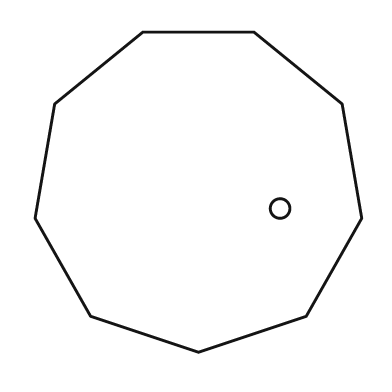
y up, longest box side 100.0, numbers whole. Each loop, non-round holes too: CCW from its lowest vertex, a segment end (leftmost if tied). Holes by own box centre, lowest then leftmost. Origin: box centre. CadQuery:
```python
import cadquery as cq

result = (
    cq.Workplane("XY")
    .moveTo(0.0, -49.0)
    .lineTo(33.0, -38.0)
    .lineTo(50.0, -8.0)
    .lineTo(44.0, 27.0)
    .lineTo(17.0, 49.0)
    .lineTo(-17.0, 49.0)
    .lineTo(-44.0, 27.0)
    .lineTo(-50.0, -8.0)
    .lineTo(-33.0, -38.0)
    .close()
    .moveTo(25.0, -5.0)
    .circle(3.0)
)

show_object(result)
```